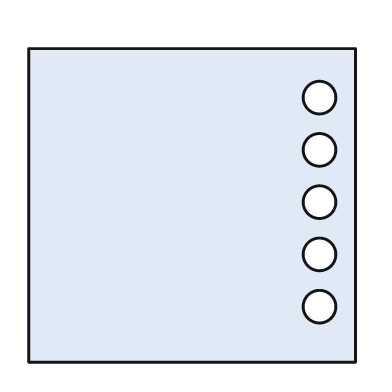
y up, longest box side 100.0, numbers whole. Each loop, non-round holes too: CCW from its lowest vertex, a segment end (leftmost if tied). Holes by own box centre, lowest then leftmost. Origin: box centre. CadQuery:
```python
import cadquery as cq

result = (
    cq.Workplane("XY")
    .moveTo(-50.0, -48.0)
    .lineTo(50.0, -48.0)
    .lineTo(50.0, 48.0)
    .lineTo(-50.0, 48.0)
    .close()
    .moveTo(39.0, -31.0)
    .circle(5.0)
    .moveTo(39.0, -15.0)
    .circle(5.0)
    .moveTo(39.0, 1.0)
    .circle(5.0)
    .moveTo(39.0, 17.0)
    .circle(5.0)
    .moveTo(39.0, 33.0)
    .circle(5.0)
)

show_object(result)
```